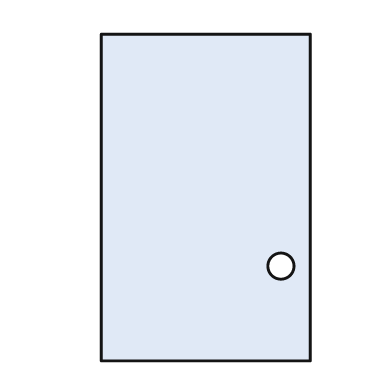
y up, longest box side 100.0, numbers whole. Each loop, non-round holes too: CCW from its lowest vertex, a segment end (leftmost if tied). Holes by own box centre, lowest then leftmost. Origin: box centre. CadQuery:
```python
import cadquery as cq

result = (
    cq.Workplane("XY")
    .moveTo(-32.0, -50.0)
    .lineTo(32.0, -50.0)
    .lineTo(32.0, 50.0)
    .lineTo(-32.0, 50.0)
    .close()
    .moveTo(23.0, -21.0)
    .circle(4.0)
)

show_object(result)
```